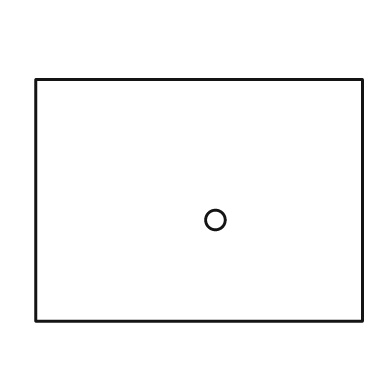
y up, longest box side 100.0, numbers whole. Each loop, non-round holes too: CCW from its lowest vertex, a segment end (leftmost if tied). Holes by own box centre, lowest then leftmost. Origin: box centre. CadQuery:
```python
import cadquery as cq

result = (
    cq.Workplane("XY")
    .moveTo(-50.0, -37.0)
    .lineTo(50.0, -37.0)
    .lineTo(50.0, 37.0)
    .lineTo(-50.0, 37.0)
    .close()
    .moveTo(5.0, -6.0)
    .circle(3.0)
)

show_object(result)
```